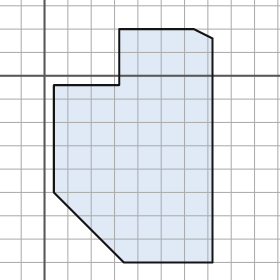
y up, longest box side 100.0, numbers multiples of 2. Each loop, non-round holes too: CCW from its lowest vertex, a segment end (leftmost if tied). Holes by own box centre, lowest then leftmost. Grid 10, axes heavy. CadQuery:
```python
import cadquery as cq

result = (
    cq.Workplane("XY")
    .moveTo(34.0, -80.0)
    .lineTo(72.0, -80.0)
    .lineTo(72.0, 16.0)
    .lineTo(64.0, 20.0)
    .lineTo(32.0, 20.0)
    .lineTo(32.0, -4.0)
    .lineTo(4.0, -4.0)
    .lineTo(4.0, -50.0)
    .close()
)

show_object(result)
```